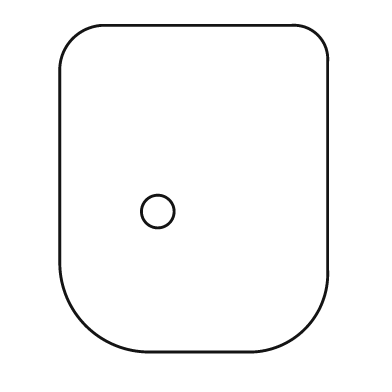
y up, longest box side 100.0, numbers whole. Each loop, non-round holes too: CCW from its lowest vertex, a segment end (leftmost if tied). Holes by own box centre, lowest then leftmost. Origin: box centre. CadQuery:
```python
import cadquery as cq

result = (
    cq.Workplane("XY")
    .moveTo(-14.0, -50.0)
    .lineTo(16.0, -50.0)
    .threePointArc((34.0, -43.0), (41.0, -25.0))
    .lineTo(41.0, 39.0)
    .threePointArc((38.0, 47.0), (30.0, 50.0))
    .lineTo(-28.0, 50.0)
    .threePointArc((-37.0, 46.0), (-41.0, 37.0))
    .lineTo(-41.0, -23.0)
    .threePointArc((-33.0, -42.0), (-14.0, -50.0))
    .close()
    .moveTo(-11.0, -7.0)
    .circle(5.0)
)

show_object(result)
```